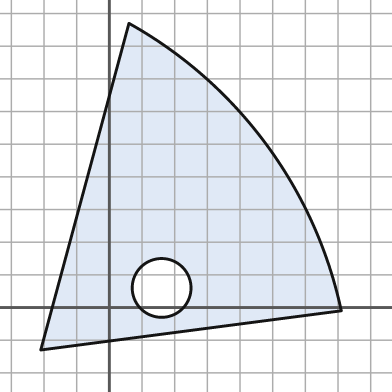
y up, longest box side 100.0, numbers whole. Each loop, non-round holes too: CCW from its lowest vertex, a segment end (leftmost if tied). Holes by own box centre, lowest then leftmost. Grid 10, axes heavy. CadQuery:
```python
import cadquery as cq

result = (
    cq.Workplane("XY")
    .moveTo(-21.0, -13.0)
    .lineTo(71.0, -1.0)
    .threePointArc((48.0, 50.0), (6.0, 87.0))
    .close()
    .moveTo(16.0, 6.0)
    .circle(9.0)
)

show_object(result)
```